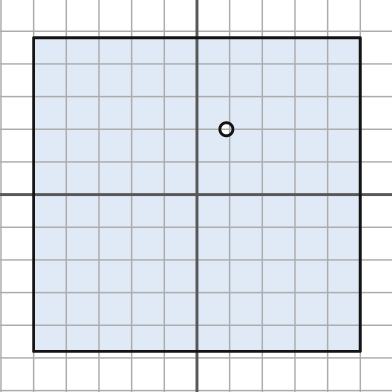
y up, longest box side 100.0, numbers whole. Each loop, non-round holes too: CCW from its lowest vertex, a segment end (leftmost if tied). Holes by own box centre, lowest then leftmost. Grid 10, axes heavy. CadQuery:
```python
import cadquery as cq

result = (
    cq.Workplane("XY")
    .moveTo(-50.0, -48.0)
    .lineTo(50.0, -48.0)
    .lineTo(50.0, 48.0)
    .lineTo(-50.0, 48.0)
    .close()
    .moveTo(9.0, 20.0)
    .circle(2.0)
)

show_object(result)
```